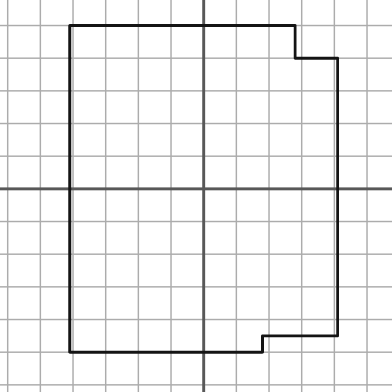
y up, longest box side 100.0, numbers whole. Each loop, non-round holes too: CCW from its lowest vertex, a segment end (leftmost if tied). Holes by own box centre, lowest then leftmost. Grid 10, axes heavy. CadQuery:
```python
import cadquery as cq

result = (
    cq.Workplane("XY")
    .moveTo(-41.0, -50.0)
    .lineTo(18.0, -50.0)
    .lineTo(18.0, -45.0)
    .lineTo(41.0, -45.0)
    .lineTo(41.0, 40.0)
    .lineTo(28.0, 40.0)
    .lineTo(28.0, 50.0)
    .lineTo(-41.0, 50.0)
    .close()
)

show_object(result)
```